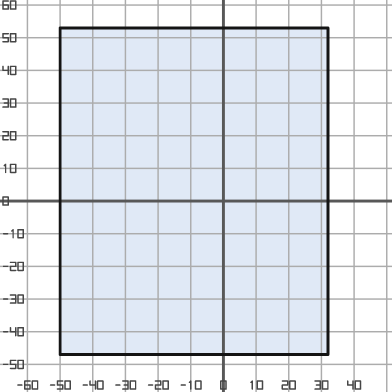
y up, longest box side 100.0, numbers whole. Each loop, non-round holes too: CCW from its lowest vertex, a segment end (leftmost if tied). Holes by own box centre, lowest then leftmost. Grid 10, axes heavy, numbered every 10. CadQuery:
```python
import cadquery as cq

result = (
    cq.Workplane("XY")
    .moveTo(-50.0, -47.0)
    .lineTo(32.0, -47.0)
    .lineTo(32.0, 53.0)
    .lineTo(-50.0, 53.0)
    .close()
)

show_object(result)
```